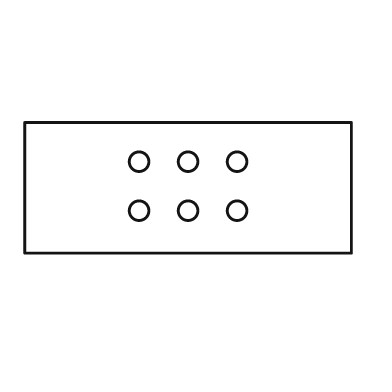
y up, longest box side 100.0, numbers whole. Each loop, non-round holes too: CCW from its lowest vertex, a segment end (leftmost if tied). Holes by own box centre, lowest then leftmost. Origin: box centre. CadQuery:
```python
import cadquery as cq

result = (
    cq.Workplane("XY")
    .moveTo(-50.0, -20.0)
    .lineTo(50.0, -20.0)
    .lineTo(50.0, 20.0)
    .lineTo(-50.0, 20.0)
    .close()
    .moveTo(-15.0, -7.0)
    .circle(3.0)
    .moveTo(0.0, -7.0)
    .circle(3.0)
    .moveTo(15.0, -7.0)
    .circle(3.0)
    .moveTo(-15.0, 8.0)
    .circle(3.0)
    .moveTo(0.0, 8.0)
    .circle(3.0)
    .moveTo(15.0, 8.0)
    .circle(3.0)
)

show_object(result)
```